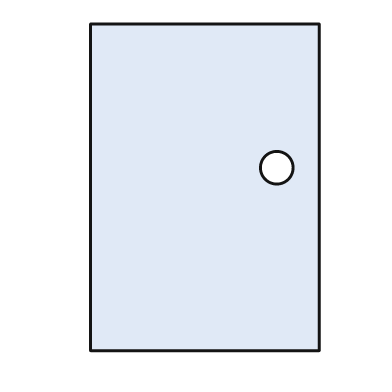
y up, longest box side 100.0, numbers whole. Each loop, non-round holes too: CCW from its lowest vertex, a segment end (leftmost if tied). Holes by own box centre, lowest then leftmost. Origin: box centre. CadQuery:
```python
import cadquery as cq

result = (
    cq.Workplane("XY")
    .moveTo(-35.0, -50.0)
    .lineTo(35.0, -50.0)
    .lineTo(35.0, 50.0)
    .lineTo(-35.0, 50.0)
    .close()
    .moveTo(22.0, 6.0)
    .circle(5.0)
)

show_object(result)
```